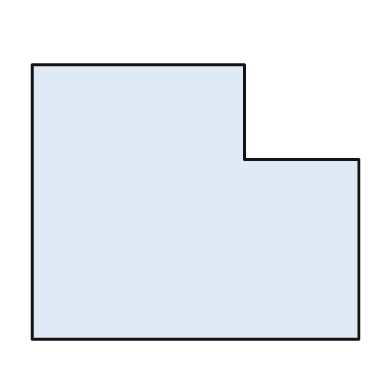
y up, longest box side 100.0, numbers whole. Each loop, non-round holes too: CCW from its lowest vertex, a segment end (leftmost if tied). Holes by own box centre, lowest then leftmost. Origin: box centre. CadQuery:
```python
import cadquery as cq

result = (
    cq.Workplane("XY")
    .moveTo(-50.0, -42.0)
    .lineTo(50.0, -42.0)
    .lineTo(50.0, 13.0)
    .lineTo(15.0, 13.0)
    .lineTo(15.0, 42.0)
    .lineTo(-50.0, 42.0)
    .close()
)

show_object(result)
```